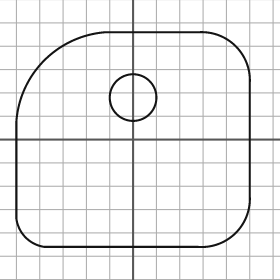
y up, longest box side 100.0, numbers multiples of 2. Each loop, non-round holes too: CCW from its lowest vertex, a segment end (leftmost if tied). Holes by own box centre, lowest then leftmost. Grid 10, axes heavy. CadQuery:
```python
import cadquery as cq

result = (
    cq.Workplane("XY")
    .moveTo(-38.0, -46.0)
    .lineTo(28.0, -46.0)
    .threePointArc((44.0, -40.0), (50.0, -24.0))
    .lineTo(50.0, 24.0)
    .threePointArc((44.0, 40.0), (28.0, 46.0))
    .lineTo(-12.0, 46.0)
    .threePointArc((-38.0, 34.0), (-50.0, 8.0))
    .lineTo(-50.0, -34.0)
    .threePointArc((-46.0, -42.0), (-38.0, -46.0))
    .close()
    .moveTo(0.0, 18.0)
    .circle(10.0)
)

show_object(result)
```